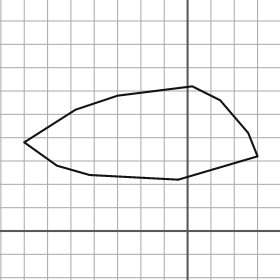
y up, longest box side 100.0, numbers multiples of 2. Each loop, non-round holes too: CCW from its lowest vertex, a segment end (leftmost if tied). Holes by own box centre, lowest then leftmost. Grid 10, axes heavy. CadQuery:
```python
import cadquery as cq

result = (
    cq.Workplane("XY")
    .moveTo(-4.0, 22.0)
    .lineTo(30.0, 32.0)
    .lineTo(26.0, 42.0)
    .lineTo(14.0, 56.0)
    .lineTo(2.0, 62.0)
    .lineTo(-30.0, 58.0)
    .lineTo(-48.0, 52.0)
    .lineTo(-70.0, 38.0)
    .lineTo(-56.0, 28.0)
    .lineTo(-42.0, 24.0)
    .close()
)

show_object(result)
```